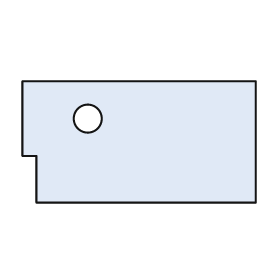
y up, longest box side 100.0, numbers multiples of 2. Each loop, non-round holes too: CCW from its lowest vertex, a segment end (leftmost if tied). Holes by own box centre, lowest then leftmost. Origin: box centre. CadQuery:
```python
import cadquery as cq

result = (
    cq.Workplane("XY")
    .moveTo(-44.0, -26.0)
    .lineTo(50.0, -26.0)
    .lineTo(50.0, 26.0)
    .lineTo(-50.0, 26.0)
    .lineTo(-50.0, -6.0)
    .lineTo(-44.0, -6.0)
    .close()
    .moveTo(-22.0, 10.0)
    .circle(6.0)
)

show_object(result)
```